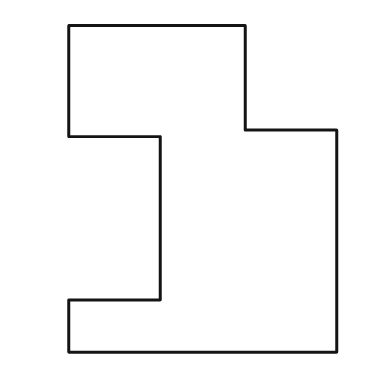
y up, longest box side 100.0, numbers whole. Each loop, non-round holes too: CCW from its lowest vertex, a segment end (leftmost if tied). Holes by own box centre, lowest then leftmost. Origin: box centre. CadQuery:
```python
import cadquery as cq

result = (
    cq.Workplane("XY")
    .moveTo(-41.0, -50.0)
    .lineTo(41.0, -50.0)
    .lineTo(41.0, 18.0)
    .lineTo(13.0, 18.0)
    .lineTo(13.0, 50.0)
    .lineTo(-41.0, 50.0)
    .lineTo(-41.0, 16.0)
    .lineTo(-13.0, 16.0)
    .lineTo(-13.0, -34.0)
    .lineTo(-41.0, -34.0)
    .close()
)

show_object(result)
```